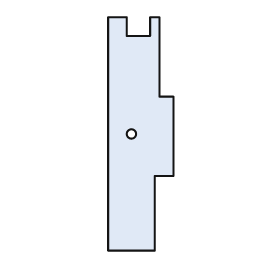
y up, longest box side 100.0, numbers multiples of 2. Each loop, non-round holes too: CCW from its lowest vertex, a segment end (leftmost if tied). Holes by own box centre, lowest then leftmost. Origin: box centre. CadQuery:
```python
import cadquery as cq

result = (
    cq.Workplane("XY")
    .moveTo(-14.0, -50.0)
    .lineTo(6.0, -50.0)
    .lineTo(6.0, -18.0)
    .lineTo(14.0, -18.0)
    .lineTo(14.0, 16.0)
    .lineTo(8.0, 16.0)
    .lineTo(8.0, 50.0)
    .lineTo(4.0, 50.0)
    .lineTo(4.0, 42.0)
    .lineTo(-6.0, 42.0)
    .lineTo(-6.0, 50.0)
    .lineTo(-14.0, 50.0)
    .close()
    .moveTo(-4.0, 0.0)
    .circle(2.0)
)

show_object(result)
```